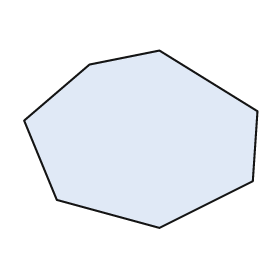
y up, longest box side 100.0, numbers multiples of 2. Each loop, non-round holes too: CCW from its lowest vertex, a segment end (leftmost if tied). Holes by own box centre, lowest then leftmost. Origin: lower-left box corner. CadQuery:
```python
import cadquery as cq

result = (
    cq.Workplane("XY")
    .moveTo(58.0, 0.0)
    .lineTo(98.0, 20.0)
    .lineTo(100.0, 50.0)
    .lineTo(58.0, 76.0)
    .lineTo(28.0, 70.0)
    .lineTo(0.0, 46.0)
    .lineTo(14.0, 12.0)
    .close()
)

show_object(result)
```